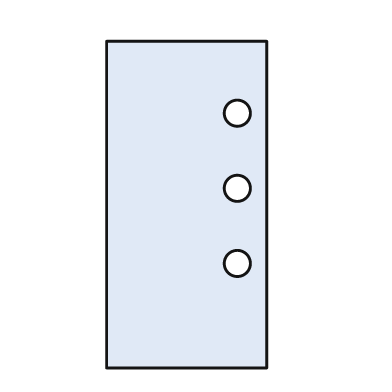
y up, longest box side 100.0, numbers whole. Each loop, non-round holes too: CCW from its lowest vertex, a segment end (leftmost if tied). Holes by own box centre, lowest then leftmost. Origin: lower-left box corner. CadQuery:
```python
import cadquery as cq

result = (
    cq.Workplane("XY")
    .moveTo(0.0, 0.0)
    .lineTo(49.0, 0.0)
    .lineTo(49.0, 100.0)
    .lineTo(0.0, 100.0)
    .close()
    .moveTo(40.0, 32.0)
    .circle(4.0)
    .moveTo(40.0, 55.0)
    .circle(4.0)
    .moveTo(40.0, 78.0)
    .circle(4.0)
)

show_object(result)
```